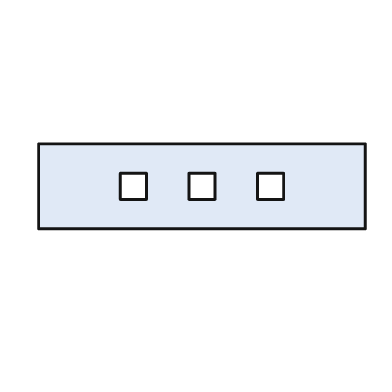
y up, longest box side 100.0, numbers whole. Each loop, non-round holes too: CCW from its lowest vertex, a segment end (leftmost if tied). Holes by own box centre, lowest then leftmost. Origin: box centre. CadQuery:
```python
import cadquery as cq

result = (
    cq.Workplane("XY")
    .moveTo(-50.0, -13.0)
    .lineTo(50.0, -13.0)
    .lineTo(50.0, 13.0)
    .lineTo(-50.0, 13.0)
    .close()
    .moveTo(-25.0, -4.0)
    .lineTo(-17.0, -4.0)
    .lineTo(-17.0, 4.0)
    .lineTo(-25.0, 4.0)
    .close()
    .moveTo(-4.0, -4.0)
    .lineTo(4.0, -4.0)
    .lineTo(4.0, 4.0)
    .lineTo(-4.0, 4.0)
    .close()
    .moveTo(17.0, -4.0)
    .lineTo(25.0, -4.0)
    .lineTo(25.0, 4.0)
    .lineTo(17.0, 4.0)
    .close()
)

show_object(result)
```